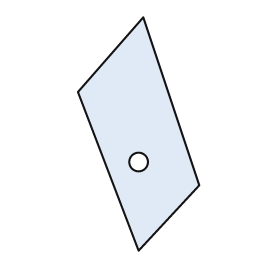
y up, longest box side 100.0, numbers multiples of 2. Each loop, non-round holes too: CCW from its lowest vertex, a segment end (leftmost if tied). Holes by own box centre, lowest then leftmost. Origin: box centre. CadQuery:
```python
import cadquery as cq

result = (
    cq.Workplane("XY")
    .moveTo(0.0, -50.0)
    .lineTo(26.0, -22.0)
    .lineTo(2.0, 50.0)
    .lineTo(-26.0, 18.0)
    .close()
    .moveTo(0.0, -12.0)
    .circle(4.0)
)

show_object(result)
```